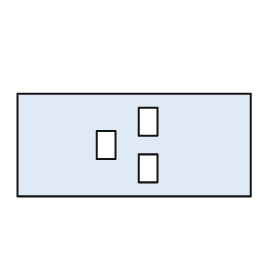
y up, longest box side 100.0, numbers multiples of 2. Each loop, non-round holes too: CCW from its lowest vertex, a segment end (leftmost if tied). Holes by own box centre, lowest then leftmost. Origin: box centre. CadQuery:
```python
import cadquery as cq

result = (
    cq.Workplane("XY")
    .moveTo(-50.0, -22.0)
    .lineTo(50.0, -22.0)
    .lineTo(50.0, 22.0)
    .lineTo(-50.0, 22.0)
    .close()
    .moveTo(2.0, -16.0)
    .lineTo(10.0, -16.0)
    .lineTo(10.0, -4.0)
    .lineTo(2.0, -4.0)
    .close()
    .moveTo(-16.0, -6.0)
    .lineTo(-8.0, -6.0)
    .lineTo(-8.0, 6.0)
    .lineTo(-16.0, 6.0)
    .close()
    .moveTo(2.0, 4.0)
    .lineTo(10.0, 4.0)
    .lineTo(10.0, 16.0)
    .lineTo(2.0, 16.0)
    .close()
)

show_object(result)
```